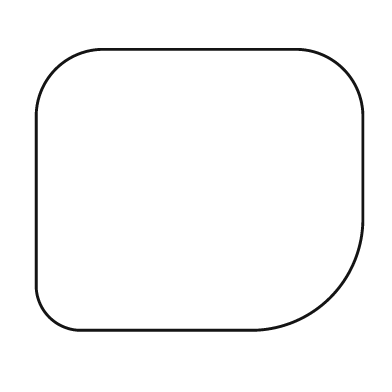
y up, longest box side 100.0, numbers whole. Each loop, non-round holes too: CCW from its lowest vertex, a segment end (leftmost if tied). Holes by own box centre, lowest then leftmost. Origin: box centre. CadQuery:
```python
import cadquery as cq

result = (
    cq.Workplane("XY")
    .moveTo(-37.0, -43.0)
    .lineTo(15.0, -43.0)
    .threePointArc((40.0, -33.0), (50.0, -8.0))
    .lineTo(50.0, 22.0)
    .threePointArc((44.0, 37.0), (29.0, 43.0))
    .lineTo(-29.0, 43.0)
    .threePointArc((-44.0, 37.0), (-50.0, 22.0))
    .lineTo(-50.0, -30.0)
    .threePointArc((-46.0, -39.0), (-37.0, -43.0))
    .close()
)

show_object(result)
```